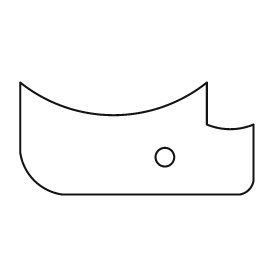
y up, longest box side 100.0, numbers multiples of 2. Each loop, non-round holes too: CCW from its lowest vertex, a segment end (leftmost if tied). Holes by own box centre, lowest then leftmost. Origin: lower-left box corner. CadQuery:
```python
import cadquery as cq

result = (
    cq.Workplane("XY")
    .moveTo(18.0, 0.0)
    .lineTo(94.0, 0.0)
    .threePointArc((98.0, 2.0), (100.0, 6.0))
    .lineTo(100.0, 30.0)
    .threePointArc((90.0, 28.0), (80.0, 30.0))
    .lineTo(80.0, 48.0)
    .threePointArc((40.0, 34.0), (0.0, 48.0))
    .lineTo(0.0, 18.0)
    .threePointArc((6.0, 6.0), (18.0, 0.0))
    .close()
    .moveTo(62.0, 16.0)
    .circle(4.0)
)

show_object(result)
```